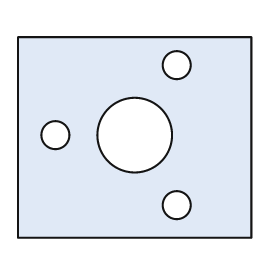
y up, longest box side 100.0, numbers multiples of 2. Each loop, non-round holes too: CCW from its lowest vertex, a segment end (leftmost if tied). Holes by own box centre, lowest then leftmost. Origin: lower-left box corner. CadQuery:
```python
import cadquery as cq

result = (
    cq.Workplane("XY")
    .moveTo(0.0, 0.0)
    .lineTo(100.0, 0.0)
    .lineTo(100.0, 86.0)
    .lineTo(0.0, 86.0)
    .close()
    .moveTo(68.0, 14.0)
    .circle(6.0)
    .moveTo(16.0, 44.0)
    .circle(6.0)
    .moveTo(50.0, 44.0)
    .circle(16.0)
    .moveTo(68.0, 74.0)
    .circle(6.0)
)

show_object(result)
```